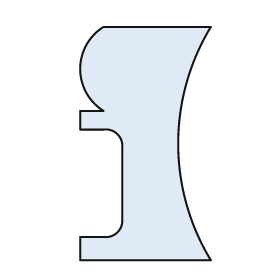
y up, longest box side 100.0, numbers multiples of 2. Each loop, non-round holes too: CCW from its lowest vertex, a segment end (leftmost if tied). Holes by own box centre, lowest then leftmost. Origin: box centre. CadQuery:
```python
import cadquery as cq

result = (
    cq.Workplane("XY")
    .moveTo(-28.0, -50.0)
    .lineTo(28.0, -50.0)
    .threePointArc((14.0, 0.0), (28.0, 50.0))
    .lineTo(-18.0, 50.0)
    .threePointArc((-28.0, 32.0), (-18.0, 14.0))
    .lineTo(-28.0, 14.0)
    .lineTo(-28.0, 6.0)
    .lineTo(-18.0, 6.0)
    .threePointArc((-12.0, 4.0), (-10.0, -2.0))
    .lineTo(-10.0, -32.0)
    .threePointArc((-12.0, -38.0), (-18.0, -40.0))
    .lineTo(-28.0, -40.0)
    .close()
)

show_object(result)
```